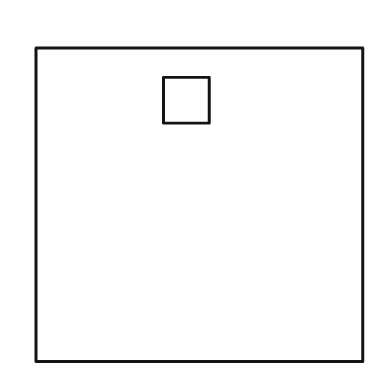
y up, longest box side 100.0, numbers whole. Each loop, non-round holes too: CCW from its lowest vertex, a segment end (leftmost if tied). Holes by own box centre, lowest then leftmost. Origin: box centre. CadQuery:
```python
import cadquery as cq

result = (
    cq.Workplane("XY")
    .moveTo(-50.0, -48.0)
    .lineTo(50.0, -48.0)
    .lineTo(50.0, 48.0)
    .lineTo(-50.0, 48.0)
    .close()
    .moveTo(-11.0, 25.0)
    .lineTo(3.0, 25.0)
    .lineTo(3.0, 39.0)
    .lineTo(-11.0, 39.0)
    .close()
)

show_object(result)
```